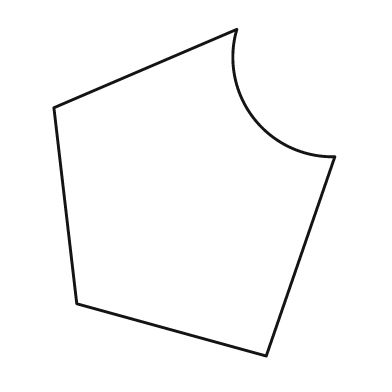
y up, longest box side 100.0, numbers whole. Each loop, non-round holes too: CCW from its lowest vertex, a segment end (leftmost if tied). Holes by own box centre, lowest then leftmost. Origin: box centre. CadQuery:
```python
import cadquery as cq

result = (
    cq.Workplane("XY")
    .moveTo(22.0, -50.0)
    .lineTo(43.0, 11.0)
    .threePointArc((18.0, 23.0), (13.0, 50.0))
    .lineTo(-43.0, 26.0)
    .lineTo(-36.0, -34.0)
    .close()
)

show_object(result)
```